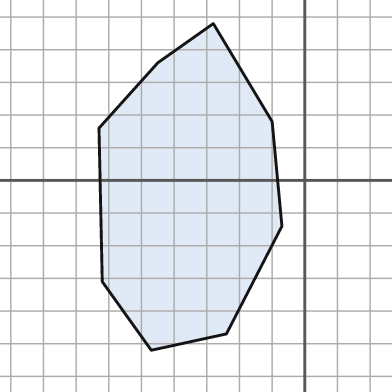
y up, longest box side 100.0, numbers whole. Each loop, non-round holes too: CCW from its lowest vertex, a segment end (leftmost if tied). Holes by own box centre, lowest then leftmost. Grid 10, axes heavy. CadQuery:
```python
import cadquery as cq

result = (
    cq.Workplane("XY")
    .moveTo(-47.0, -52.0)
    .lineTo(-24.0, -47.0)
    .lineTo(-7.0, -14.0)
    .lineTo(-10.0, 18.0)
    .lineTo(-28.0, 48.0)
    .lineTo(-45.0, 36.0)
    .lineTo(-63.0, 16.0)
    .lineTo(-62.0, -31.0)
    .close()
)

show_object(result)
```